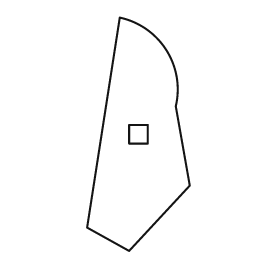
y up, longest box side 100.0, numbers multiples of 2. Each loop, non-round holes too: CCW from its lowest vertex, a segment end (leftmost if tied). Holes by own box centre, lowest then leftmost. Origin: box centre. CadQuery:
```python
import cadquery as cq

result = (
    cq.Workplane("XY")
    .moveTo(-4.0, -50.0)
    .lineTo(22.0, -22.0)
    .lineTo(16.0, 12.0)
    .threePointArc((12.0, 36.0), (-8.0, 50.0))
    .lineTo(-22.0, -40.0)
    .close()
    .moveTo(-4.0, -4.0)
    .lineTo(4.0, -4.0)
    .lineTo(4.0, 4.0)
    .lineTo(-4.0, 4.0)
    .close()
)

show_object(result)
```